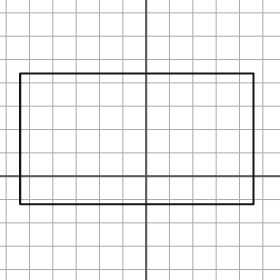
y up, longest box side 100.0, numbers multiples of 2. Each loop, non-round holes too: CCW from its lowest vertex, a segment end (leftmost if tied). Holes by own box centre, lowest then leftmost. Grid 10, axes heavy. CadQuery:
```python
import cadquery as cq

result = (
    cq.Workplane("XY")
    .moveTo(-54.0, -12.0)
    .lineTo(46.0, -12.0)
    .lineTo(46.0, 44.0)
    .lineTo(-54.0, 44.0)
    .close()
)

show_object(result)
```